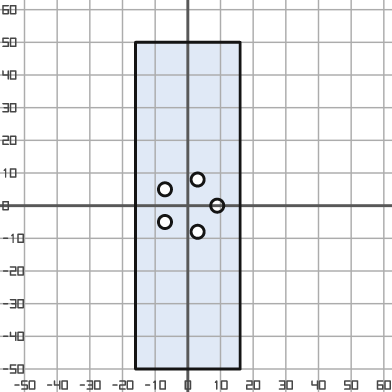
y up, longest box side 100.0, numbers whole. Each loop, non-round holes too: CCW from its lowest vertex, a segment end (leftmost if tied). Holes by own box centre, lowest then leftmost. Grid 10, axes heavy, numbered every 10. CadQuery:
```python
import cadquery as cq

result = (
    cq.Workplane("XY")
    .moveTo(-16.0, -50.0)
    .lineTo(16.0, -50.0)
    .lineTo(16.0, 50.0)
    .lineTo(-16.0, 50.0)
    .close()
    .moveTo(3.0, -8.0)
    .circle(2.0)
    .moveTo(-7.0, -5.0)
    .circle(2.0)
    .moveTo(9.0, 0.0)
    .circle(2.0)
    .moveTo(-7.0, 5.0)
    .circle(2.0)
    .moveTo(3.0, 8.0)
    .circle(2.0)
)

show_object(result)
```